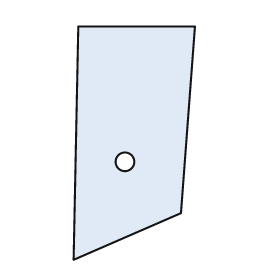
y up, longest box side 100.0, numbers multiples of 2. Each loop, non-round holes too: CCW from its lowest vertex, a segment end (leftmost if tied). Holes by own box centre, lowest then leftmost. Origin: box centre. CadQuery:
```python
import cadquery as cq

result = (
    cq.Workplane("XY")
    .moveTo(-26.0, -50.0)
    .lineTo(20.0, -30.0)
    .lineTo(26.0, 50.0)
    .lineTo(-24.0, 50.0)
    .close()
    .moveTo(-4.0, -8.0)
    .circle(4.0)
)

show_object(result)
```